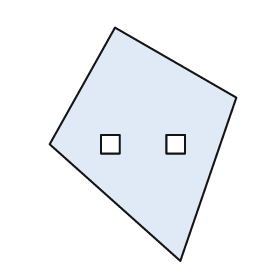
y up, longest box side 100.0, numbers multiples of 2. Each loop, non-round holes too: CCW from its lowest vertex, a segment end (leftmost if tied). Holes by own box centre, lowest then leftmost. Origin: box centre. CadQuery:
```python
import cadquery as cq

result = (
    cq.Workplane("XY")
    .moveTo(16.0, -50.0)
    .lineTo(40.0, 20.0)
    .lineTo(-12.0, 50.0)
    .lineTo(-40.0, 0.0)
    .close()
    .moveTo(-18.0, -4.0)
    .lineTo(-10.0, -4.0)
    .lineTo(-10.0, 4.0)
    .lineTo(-18.0, 4.0)
    .close()
    .moveTo(10.0, -4.0)
    .lineTo(18.0, -4.0)
    .lineTo(18.0, 4.0)
    .lineTo(10.0, 4.0)
    .close()
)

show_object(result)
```